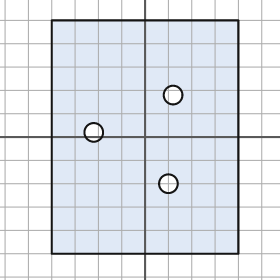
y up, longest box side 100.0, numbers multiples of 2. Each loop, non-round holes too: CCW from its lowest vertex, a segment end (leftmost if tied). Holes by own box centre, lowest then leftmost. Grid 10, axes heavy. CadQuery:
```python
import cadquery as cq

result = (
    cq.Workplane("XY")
    .moveTo(-40.0, -50.0)
    .lineTo(40.0, -50.0)
    .lineTo(40.0, 50.0)
    .lineTo(-40.0, 50.0)
    .close()
    .moveTo(10.0, -20.0)
    .circle(4.0)
    .moveTo(-22.0, 2.0)
    .circle(4.0)
    .moveTo(12.0, 18.0)
    .circle(4.0)
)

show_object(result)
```